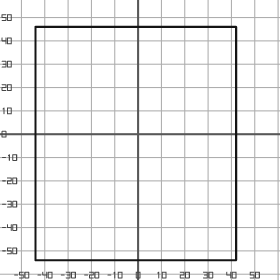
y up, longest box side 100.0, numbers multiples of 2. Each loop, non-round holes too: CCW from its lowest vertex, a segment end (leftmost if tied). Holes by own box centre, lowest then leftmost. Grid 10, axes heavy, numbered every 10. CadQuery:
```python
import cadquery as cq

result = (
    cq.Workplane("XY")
    .moveTo(-44.0, -54.0)
    .lineTo(42.0, -54.0)
    .lineTo(42.0, 46.0)
    .lineTo(-44.0, 46.0)
    .close()
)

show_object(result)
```